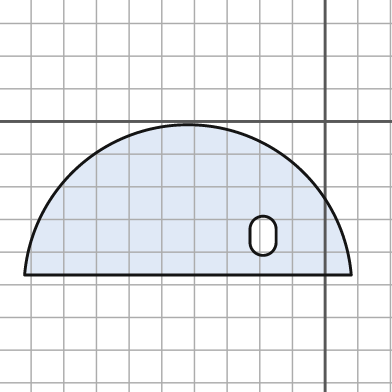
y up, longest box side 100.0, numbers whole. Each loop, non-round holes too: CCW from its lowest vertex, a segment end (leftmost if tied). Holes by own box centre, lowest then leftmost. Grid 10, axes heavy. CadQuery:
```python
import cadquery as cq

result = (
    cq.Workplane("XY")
    .moveTo(-92.0, -47.0)
    .lineTo(8.0, -47.0)
    .threePointArc((-42.0, -1.0), (-92.0, -47.0))
    .close()
    .moveTo(-23.0, -37.0)
    .threePointArc((-19.0, -41.0), (-15.0, -37.0))
    .lineTo(-15.0, -33.0)
    .threePointArc((-19.0, -29.0), (-23.0, -33.0))
    .close()
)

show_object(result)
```